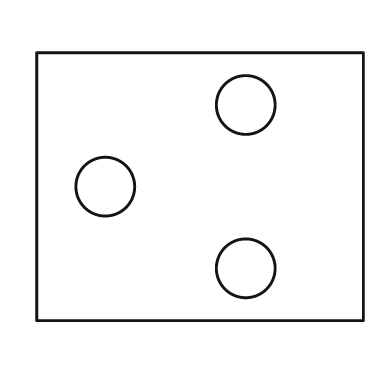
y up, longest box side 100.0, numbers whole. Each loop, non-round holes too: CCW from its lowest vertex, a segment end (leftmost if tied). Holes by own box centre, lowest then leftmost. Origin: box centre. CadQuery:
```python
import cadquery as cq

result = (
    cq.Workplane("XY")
    .moveTo(-50.0, -41.0)
    .lineTo(50.0, -41.0)
    .lineTo(50.0, 41.0)
    .lineTo(-50.0, 41.0)
    .close()
    .moveTo(14.0, -25.0)
    .circle(9.0)
    .moveTo(-29.0, 0.0)
    .circle(9.0)
    .moveTo(14.0, 25.0)
    .circle(9.0)
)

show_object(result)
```